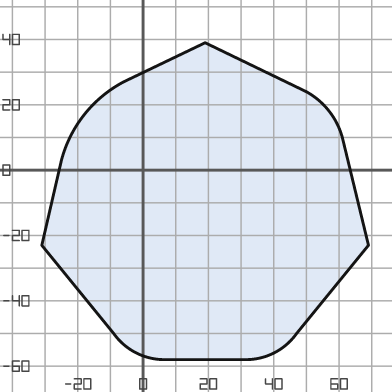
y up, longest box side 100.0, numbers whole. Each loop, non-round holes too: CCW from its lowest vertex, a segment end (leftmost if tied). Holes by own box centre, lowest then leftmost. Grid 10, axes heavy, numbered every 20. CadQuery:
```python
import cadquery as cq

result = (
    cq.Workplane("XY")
    .moveTo(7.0, -58.0)
    .lineTo(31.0, -58.0)
    .threePointArc((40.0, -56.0), (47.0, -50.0))
    .lineTo(69.0, -23.0)
    .lineTo(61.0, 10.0)
    .threePointArc((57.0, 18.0), (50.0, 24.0))
    .lineTo(19.0, 39.0)
    .lineTo(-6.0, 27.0)
    .threePointArc((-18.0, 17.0), (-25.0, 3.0))
    .lineTo(-31.0, -23.0)
    .lineTo(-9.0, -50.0)
    .threePointArc((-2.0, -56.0), (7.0, -58.0))
    .close()
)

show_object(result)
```